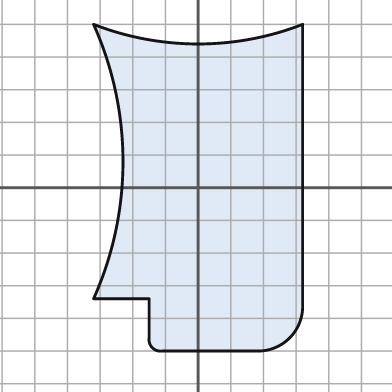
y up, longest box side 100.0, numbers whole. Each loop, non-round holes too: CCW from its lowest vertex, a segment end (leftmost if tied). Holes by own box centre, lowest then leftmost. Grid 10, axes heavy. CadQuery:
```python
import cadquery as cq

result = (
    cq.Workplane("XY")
    .moveTo(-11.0, -50.0)
    .lineTo(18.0, -50.0)
    .threePointArc((28.0, -46.0), (32.0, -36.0))
    .lineTo(32.0, 50.0)
    .threePointArc((0.0, 44.0), (-32.0, 50.0))
    .threePointArc((-23.0, 8.0), (-32.0, -34.0))
    .lineTo(-15.0, -34.0)
    .lineTo(-15.0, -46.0)
    .threePointArc((-14.0, -49.0), (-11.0, -50.0))
    .close()
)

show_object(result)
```